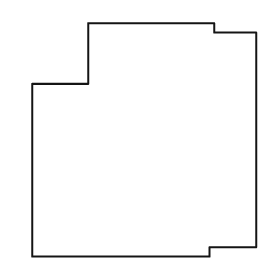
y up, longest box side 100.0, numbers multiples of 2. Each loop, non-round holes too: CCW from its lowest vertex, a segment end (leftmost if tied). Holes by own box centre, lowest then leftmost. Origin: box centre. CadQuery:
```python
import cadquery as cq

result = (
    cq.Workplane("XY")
    .moveTo(-48.0, -50.0)
    .lineTo(28.0, -50.0)
    .lineTo(28.0, -46.0)
    .lineTo(48.0, -46.0)
    .lineTo(48.0, 46.0)
    .lineTo(30.0, 46.0)
    .lineTo(30.0, 50.0)
    .lineTo(-24.0, 50.0)
    .lineTo(-24.0, 24.0)
    .lineTo(-48.0, 24.0)
    .close()
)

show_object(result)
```